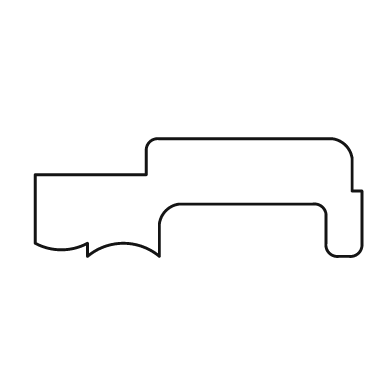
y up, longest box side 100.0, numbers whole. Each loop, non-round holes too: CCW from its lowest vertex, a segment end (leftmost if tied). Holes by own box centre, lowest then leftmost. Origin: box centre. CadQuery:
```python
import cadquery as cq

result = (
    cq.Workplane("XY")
    .moveTo(-34.0, -18.0)
    .threePointArc((-23.0, -14.0), (-12.0, -18.0))
    .lineTo(-12.0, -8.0)
    .threePointArc((-10.0, -4.0), (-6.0, -2.0))
    .lineTo(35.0, -2.0)
    .threePointArc((38.0, -3.0), (39.0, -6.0))
    .lineTo(39.0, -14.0)
    .threePointArc((40.0, -17.0), (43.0, -18.0))
    .lineTo(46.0, -18.0)
    .threePointArc((49.0, -17.0), (50.0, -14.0))
    .lineTo(50.0, 2.0)
    .lineTo(47.0, 2.0)
    .lineTo(47.0, 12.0)
    .threePointArc((45.0, 16.0), (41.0, 18.0))
    .lineTo(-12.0, 18.0)
    .threePointArc((-15.0, 17.0), (-16.0, 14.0))
    .lineTo(-16.0, 7.0)
    .lineTo(-50.0, 7.0)
    .lineTo(-50.0, -14.0)
    .threePointArc((-42.0, -16.0), (-34.0, -14.0))
    .close()
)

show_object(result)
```